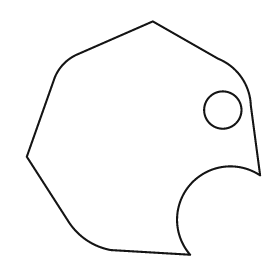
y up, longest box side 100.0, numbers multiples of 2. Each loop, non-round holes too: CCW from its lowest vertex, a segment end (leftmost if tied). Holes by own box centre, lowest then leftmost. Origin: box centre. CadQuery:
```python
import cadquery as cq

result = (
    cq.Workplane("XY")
    .moveTo(20.0, -50.0)
    .threePointArc((20.0, -20.0), (50.0, -16.0))
    .lineTo(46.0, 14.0)
    .threePointArc((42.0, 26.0), (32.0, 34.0))
    .lineTo(4.0, 50.0)
    .lineTo(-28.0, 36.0)
    .threePointArc((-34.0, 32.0), (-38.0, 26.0))
    .lineTo(-50.0, -8.0)
    .lineTo(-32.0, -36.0)
    .threePointArc((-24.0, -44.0), (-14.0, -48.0))
    .close()
    .moveTo(34.0, 12.0)
    .circle(8.0)
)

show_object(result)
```